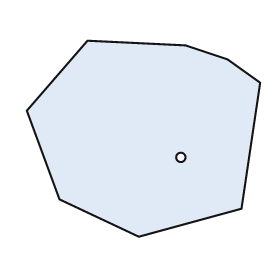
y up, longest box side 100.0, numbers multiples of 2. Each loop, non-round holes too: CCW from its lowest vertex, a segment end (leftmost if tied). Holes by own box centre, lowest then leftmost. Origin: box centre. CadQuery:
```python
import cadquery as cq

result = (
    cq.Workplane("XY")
    .moveTo(-2.0, -42.0)
    .lineTo(42.0, -30.0)
    .lineTo(50.0, 24.0)
    .lineTo(36.0, 34.0)
    .lineTo(18.0, 40.0)
    .lineTo(-24.0, 42.0)
    .lineTo(-50.0, 12.0)
    .lineTo(-36.0, -26.0)
    .close()
    .moveTo(16.0, -8.0)
    .circle(2.0)
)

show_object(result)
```